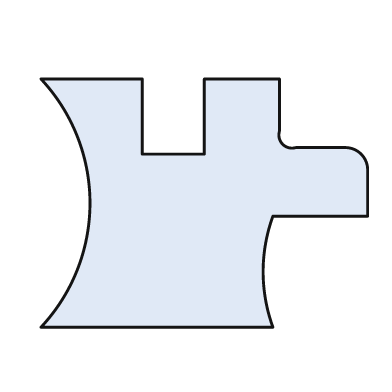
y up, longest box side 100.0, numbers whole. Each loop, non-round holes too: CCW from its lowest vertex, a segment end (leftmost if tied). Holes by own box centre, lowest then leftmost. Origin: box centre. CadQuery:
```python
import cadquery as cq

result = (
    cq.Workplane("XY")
    .moveTo(-50.0, -38.0)
    .lineTo(21.0, -38.0)
    .threePointArc((18.0, -21.0), (21.0, -4.0))
    .lineTo(50.0, -4.0)
    .lineTo(50.0, 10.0)
    .threePointArc((48.0, 15.0), (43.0, 17.0))
    .lineTo(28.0, 17.0)
    .threePointArc((24.0, 18.0), (23.0, 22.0))
    .lineTo(23.0, 38.0)
    .lineTo(0.0, 38.0)
    .lineTo(0.0, 15.0)
    .lineTo(-19.0, 15.0)
    .lineTo(-19.0, 38.0)
    .lineTo(-50.0, 38.0)
    .threePointArc((-35.0, 0.0), (-50.0, -38.0))
    .close()
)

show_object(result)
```